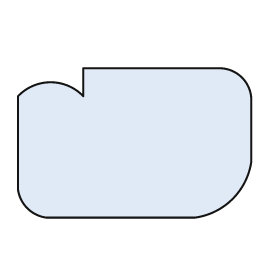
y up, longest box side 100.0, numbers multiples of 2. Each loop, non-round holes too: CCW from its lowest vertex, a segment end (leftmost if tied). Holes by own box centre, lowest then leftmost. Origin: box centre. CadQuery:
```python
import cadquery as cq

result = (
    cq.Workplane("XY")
    .moveTo(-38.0, -32.0)
    .lineTo(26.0, -32.0)
    .threePointArc((42.0, -24.0), (50.0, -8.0))
    .lineTo(50.0, 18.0)
    .threePointArc((46.0, 28.0), (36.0, 32.0))
    .lineTo(-22.0, 32.0)
    .lineTo(-22.0, 20.0)
    .threePointArc((-36.0, 26.0), (-50.0, 20.0))
    .lineTo(-50.0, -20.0)
    .threePointArc((-46.0, -28.0), (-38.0, -32.0))
    .close()
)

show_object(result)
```